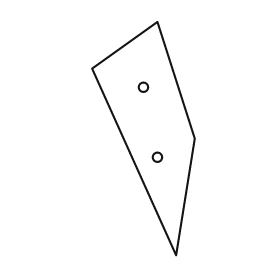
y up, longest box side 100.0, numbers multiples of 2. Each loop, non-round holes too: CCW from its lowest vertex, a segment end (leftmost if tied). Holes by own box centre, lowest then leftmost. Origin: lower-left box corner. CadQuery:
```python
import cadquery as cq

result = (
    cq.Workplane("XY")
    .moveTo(36.0, 0.0)
    .lineTo(44.0, 50.0)
    .lineTo(28.0, 100.0)
    .lineTo(0.0, 80.0)
    .close()
    .moveTo(28.0, 42.0)
    .circle(2.0)
    .moveTo(22.0, 72.0)
    .circle(2.0)
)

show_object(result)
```